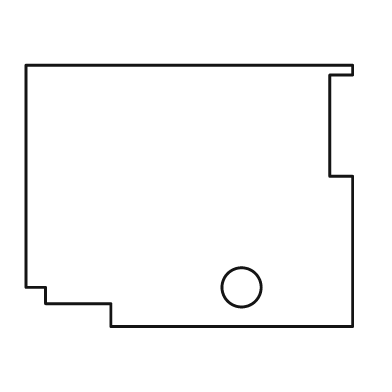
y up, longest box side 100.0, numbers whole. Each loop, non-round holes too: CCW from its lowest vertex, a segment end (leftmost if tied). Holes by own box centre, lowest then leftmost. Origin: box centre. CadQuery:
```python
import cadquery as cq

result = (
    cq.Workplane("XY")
    .moveTo(-24.0, -40.0)
    .lineTo(50.0, -40.0)
    .lineTo(50.0, 6.0)
    .lineTo(43.0, 6.0)
    .lineTo(43.0, 37.0)
    .lineTo(50.0, 37.0)
    .lineTo(50.0, 40.0)
    .lineTo(-50.0, 40.0)
    .lineTo(-50.0, -28.0)
    .lineTo(-44.0, -28.0)
    .lineTo(-44.0, -33.0)
    .lineTo(-24.0, -33.0)
    .close()
    .moveTo(16.0, -28.0)
    .circle(6.0)
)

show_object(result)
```